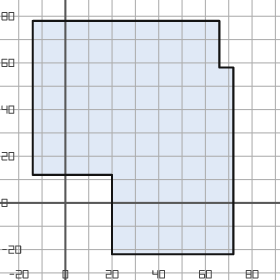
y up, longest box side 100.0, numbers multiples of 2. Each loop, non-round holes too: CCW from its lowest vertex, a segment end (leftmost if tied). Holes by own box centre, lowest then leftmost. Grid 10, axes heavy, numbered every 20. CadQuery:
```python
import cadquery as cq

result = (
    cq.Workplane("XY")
    .moveTo(20.0, -22.0)
    .lineTo(72.0, -22.0)
    .lineTo(72.0, 58.0)
    .lineTo(66.0, 58.0)
    .lineTo(66.0, 78.0)
    .lineTo(-14.0, 78.0)
    .lineTo(-14.0, 12.0)
    .lineTo(20.0, 12.0)
    .close()
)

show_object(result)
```